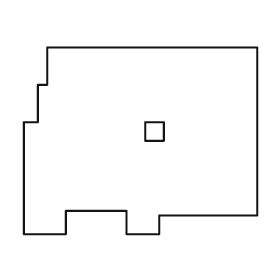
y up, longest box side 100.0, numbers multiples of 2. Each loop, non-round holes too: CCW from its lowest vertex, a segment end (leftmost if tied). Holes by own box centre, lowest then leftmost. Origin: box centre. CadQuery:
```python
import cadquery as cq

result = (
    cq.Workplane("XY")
    .moveTo(-50.0, -40.0)
    .lineTo(-32.0, -40.0)
    .lineTo(-32.0, -30.0)
    .lineTo(-6.0, -30.0)
    .lineTo(-6.0, -40.0)
    .lineTo(8.0, -40.0)
    .lineTo(8.0, -32.0)
    .lineTo(50.0, -32.0)
    .lineTo(50.0, 40.0)
    .lineTo(-40.0, 40.0)
    .lineTo(-40.0, 24.0)
    .lineTo(-44.0, 24.0)
    .lineTo(-44.0, 8.0)
    .lineTo(-50.0, 8.0)
    .close()
    .moveTo(2.0, 0.0)
    .lineTo(10.0, 0.0)
    .lineTo(10.0, 8.0)
    .lineTo(2.0, 8.0)
    .close()
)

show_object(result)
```